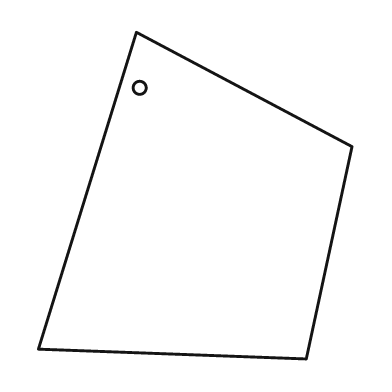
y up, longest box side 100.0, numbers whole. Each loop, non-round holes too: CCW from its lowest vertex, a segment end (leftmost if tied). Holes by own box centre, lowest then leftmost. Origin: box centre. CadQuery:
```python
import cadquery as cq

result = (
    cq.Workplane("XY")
    .moveTo(34.0, -50.0)
    .lineTo(48.0, 15.0)
    .lineTo(-18.0, 50.0)
    .lineTo(-48.0, -47.0)
    .close()
    .moveTo(-17.0, 33.0)
    .circle(2.0)
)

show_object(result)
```